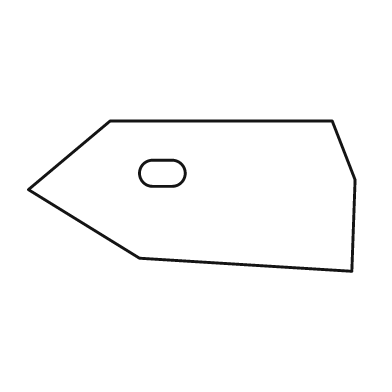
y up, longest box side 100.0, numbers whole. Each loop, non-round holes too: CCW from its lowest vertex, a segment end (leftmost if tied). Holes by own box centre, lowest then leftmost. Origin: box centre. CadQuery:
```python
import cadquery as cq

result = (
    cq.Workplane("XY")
    .moveTo(49.0, -23.0)
    .lineTo(50.0, 5.0)
    .lineTo(43.0, 23.0)
    .lineTo(-25.0, 23.0)
    .lineTo(-50.0, 2.0)
    .lineTo(-16.0, -19.0)
    .close()
    .moveTo(-12.0, 3.0)
    .lineTo(-6.0, 3.0)
    .threePointArc((-2.0, 7.0), (-6.0, 11.0))
    .lineTo(-12.0, 11.0)
    .threePointArc((-16.0, 7.0), (-12.0, 3.0))
    .close()
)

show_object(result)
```